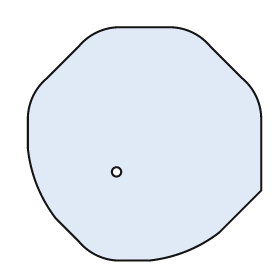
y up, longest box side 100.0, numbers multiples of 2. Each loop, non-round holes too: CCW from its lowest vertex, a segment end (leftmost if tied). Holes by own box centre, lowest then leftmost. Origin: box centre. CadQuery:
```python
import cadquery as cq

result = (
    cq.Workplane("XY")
    .moveTo(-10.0, -50.0)
    .lineTo(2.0, -50.0)
    .threePointArc((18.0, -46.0), (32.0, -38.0))
    .lineTo(50.0, -20.0)
    .lineTo(50.0, 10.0)
    .threePointArc((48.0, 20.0), (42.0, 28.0))
    .lineTo(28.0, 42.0)
    .threePointArc((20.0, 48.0), (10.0, 50.0))
    .lineTo(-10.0, 50.0)
    .threePointArc((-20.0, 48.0), (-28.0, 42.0))
    .lineTo(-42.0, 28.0)
    .threePointArc((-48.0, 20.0), (-50.0, 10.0))
    .lineTo(-50.0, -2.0)
    .threePointArc((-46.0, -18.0), (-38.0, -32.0))
    .lineTo(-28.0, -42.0)
    .threePointArc((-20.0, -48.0), (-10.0, -50.0))
    .close()
    .moveTo(-12.0, -12.0)
    .circle(2.0)
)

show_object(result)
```